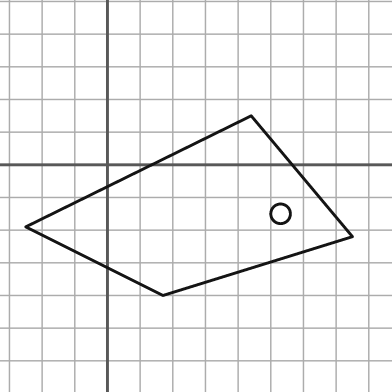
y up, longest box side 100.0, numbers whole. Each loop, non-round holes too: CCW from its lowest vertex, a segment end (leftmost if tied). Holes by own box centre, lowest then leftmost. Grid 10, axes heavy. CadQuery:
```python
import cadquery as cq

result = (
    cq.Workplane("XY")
    .moveTo(17.0, -40.0)
    .lineTo(75.0, -22.0)
    .lineTo(44.0, 15.0)
    .lineTo(-25.0, -19.0)
    .close()
    .moveTo(53.0, -15.0)
    .circle(3.0)
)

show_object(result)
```